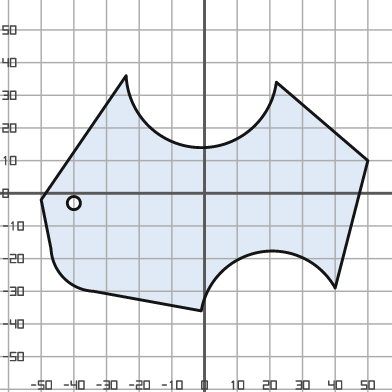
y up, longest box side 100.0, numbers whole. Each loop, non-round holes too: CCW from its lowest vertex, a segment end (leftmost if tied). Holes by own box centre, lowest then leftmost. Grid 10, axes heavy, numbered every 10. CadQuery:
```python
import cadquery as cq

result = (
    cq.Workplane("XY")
    .moveTo(-1.0, -36.0)
    .threePointArc((17.0, -18.0), (40.0, -29.0))
    .lineTo(50.0, 10.0)
    .lineTo(22.0, 34.0)
    .threePointArc((-2.0, 14.0), (-24.0, 36.0))
    .lineTo(-50.0, -2.0)
    .lineTo(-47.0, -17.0)
    .threePointArc((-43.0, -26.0), (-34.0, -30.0))
    .close()
    .moveTo(-40.0, -3.0)
    .circle(2.0)
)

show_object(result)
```